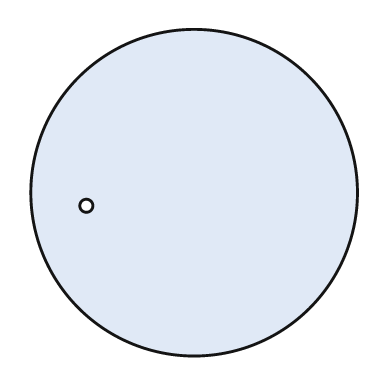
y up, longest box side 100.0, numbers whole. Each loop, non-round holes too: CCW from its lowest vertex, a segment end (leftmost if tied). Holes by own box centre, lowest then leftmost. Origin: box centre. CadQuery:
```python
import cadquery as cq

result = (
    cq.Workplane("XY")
    .moveTo(0.0, 0.0)
    .circle(50.0)
    .moveTo(-33.0, -4.0)
    .circle(2.0)
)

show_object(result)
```